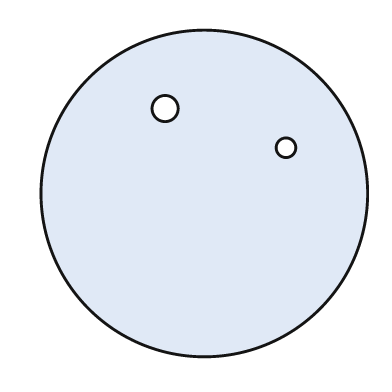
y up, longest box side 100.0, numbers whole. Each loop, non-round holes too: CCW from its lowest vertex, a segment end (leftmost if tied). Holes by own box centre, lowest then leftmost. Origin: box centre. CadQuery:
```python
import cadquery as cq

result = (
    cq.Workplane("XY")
    .moveTo(0.0, 0.0)
    .circle(50.0)
    .moveTo(25.0, 14.0)
    .circle(3.0)
    .moveTo(-12.0, 26.0)
    .circle(4.0)
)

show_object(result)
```